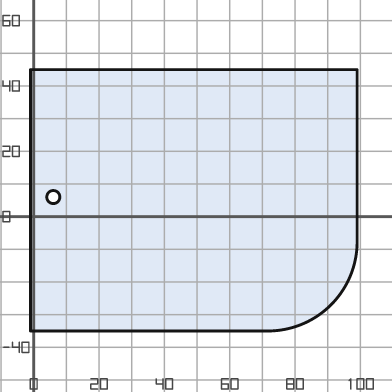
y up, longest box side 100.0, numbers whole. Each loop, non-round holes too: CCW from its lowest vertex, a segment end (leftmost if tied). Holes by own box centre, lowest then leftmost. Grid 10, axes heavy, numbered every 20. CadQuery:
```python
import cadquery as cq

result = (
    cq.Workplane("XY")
    .moveTo(-1.0, -35.0)
    .lineTo(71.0, -35.0)
    .threePointArc((91.0, -27.0), (99.0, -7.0))
    .lineTo(99.0, 45.0)
    .lineTo(-1.0, 45.0)
    .close()
    .moveTo(6.0, 6.0)
    .circle(2.0)
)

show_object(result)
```